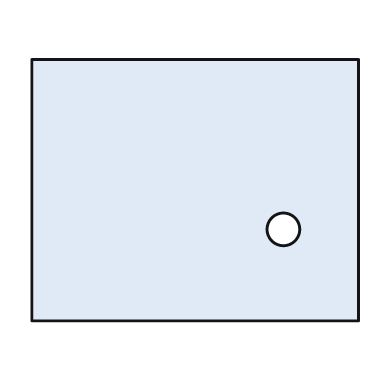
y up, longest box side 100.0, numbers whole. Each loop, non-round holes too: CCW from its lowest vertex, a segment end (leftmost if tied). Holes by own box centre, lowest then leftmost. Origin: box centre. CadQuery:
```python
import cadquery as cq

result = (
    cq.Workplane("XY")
    .moveTo(-50.0, -40.0)
    .lineTo(50.0, -40.0)
    .lineTo(50.0, 40.0)
    .lineTo(-50.0, 40.0)
    .close()
    .moveTo(27.0, -12.0)
    .circle(5.0)
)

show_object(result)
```